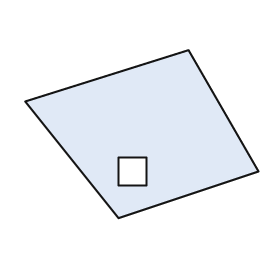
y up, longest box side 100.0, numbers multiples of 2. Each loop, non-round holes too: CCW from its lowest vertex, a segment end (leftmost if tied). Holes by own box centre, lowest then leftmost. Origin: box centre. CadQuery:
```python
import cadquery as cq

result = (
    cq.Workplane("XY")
    .moveTo(-10.0, -36.0)
    .lineTo(50.0, -16.0)
    .lineTo(20.0, 36.0)
    .lineTo(-50.0, 14.0)
    .close()
    .moveTo(-10.0, -22.0)
    .lineTo(2.0, -22.0)
    .lineTo(2.0, -10.0)
    .lineTo(-10.0, -10.0)
    .close()
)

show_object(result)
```